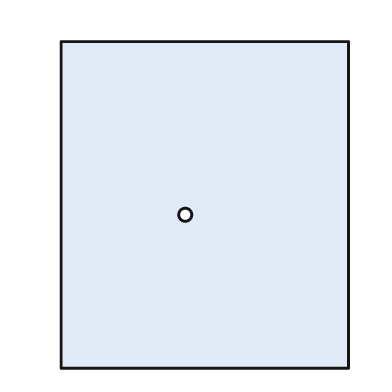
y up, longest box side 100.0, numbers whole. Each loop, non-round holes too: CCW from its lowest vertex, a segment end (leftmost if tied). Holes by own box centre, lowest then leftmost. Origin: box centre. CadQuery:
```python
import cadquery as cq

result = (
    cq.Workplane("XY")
    .moveTo(-44.0, -50.0)
    .lineTo(44.0, -50.0)
    .lineTo(44.0, 50.0)
    .lineTo(-44.0, 50.0)
    .close()
    .moveTo(-6.0, -3.0)
    .circle(2.0)
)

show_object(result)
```